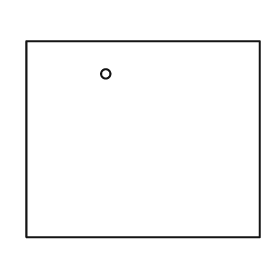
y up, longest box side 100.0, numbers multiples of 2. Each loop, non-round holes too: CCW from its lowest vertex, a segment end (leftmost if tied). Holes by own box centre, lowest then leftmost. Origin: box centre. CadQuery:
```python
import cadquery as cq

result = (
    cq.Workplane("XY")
    .moveTo(-50.0, -42.0)
    .lineTo(50.0, -42.0)
    .lineTo(50.0, 42.0)
    .lineTo(-50.0, 42.0)
    .close()
    .moveTo(-16.0, 28.0)
    .circle(2.0)
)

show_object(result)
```